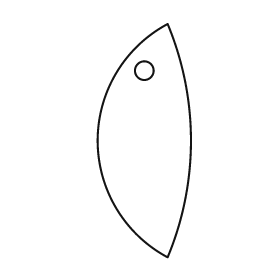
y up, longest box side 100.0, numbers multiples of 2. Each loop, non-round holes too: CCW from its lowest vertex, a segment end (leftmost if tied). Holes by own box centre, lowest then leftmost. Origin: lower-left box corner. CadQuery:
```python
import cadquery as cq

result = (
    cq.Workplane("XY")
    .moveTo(30.0, 0.0)
    .threePointArc((40.0, 50.0), (30.0, 100.0))
    .threePointArc((0.0, 50.0), (30.0, 0.0))
    .close()
    .moveTo(20.0, 80.0)
    .circle(4.0)
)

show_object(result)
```